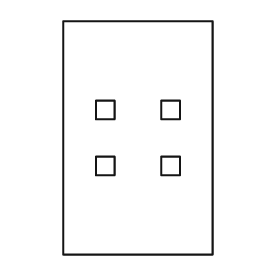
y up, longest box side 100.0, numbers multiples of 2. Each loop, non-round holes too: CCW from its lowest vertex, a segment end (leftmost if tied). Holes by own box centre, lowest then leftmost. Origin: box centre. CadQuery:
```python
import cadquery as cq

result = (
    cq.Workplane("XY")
    .moveTo(-32.0, -50.0)
    .lineTo(32.0, -50.0)
    .lineTo(32.0, 50.0)
    .lineTo(-32.0, 50.0)
    .close()
    .moveTo(-18.0, -16.0)
    .lineTo(-10.0, -16.0)
    .lineTo(-10.0, -8.0)
    .lineTo(-18.0, -8.0)
    .close()
    .moveTo(10.0, -16.0)
    .lineTo(18.0, -16.0)
    .lineTo(18.0, -8.0)
    .lineTo(10.0, -8.0)
    .close()
    .moveTo(-18.0, 8.0)
    .lineTo(-10.0, 8.0)
    .lineTo(-10.0, 16.0)
    .lineTo(-18.0, 16.0)
    .close()
    .moveTo(10.0, 8.0)
    .lineTo(18.0, 8.0)
    .lineTo(18.0, 16.0)
    .lineTo(10.0, 16.0)
    .close()
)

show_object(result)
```